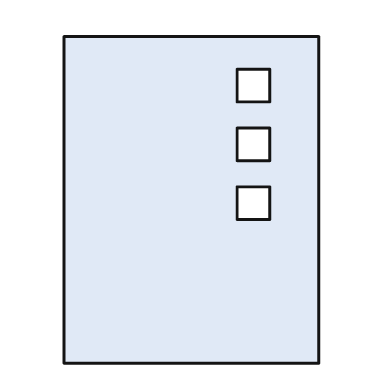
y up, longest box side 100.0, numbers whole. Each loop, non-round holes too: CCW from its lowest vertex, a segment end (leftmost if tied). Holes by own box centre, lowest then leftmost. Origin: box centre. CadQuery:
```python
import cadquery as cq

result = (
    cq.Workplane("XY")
    .moveTo(-39.0, -50.0)
    .lineTo(39.0, -50.0)
    .lineTo(39.0, 50.0)
    .lineTo(-39.0, 50.0)
    .close()
    .moveTo(14.0, -6.0)
    .lineTo(24.0, -6.0)
    .lineTo(24.0, 4.0)
    .lineTo(14.0, 4.0)
    .close()
    .moveTo(14.0, 12.0)
    .lineTo(24.0, 12.0)
    .lineTo(24.0, 22.0)
    .lineTo(14.0, 22.0)
    .close()
    .moveTo(14.0, 30.0)
    .lineTo(24.0, 30.0)
    .lineTo(24.0, 40.0)
    .lineTo(14.0, 40.0)
    .close()
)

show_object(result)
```